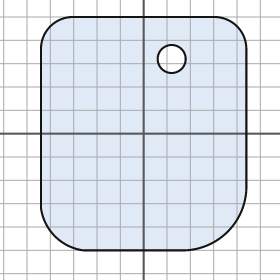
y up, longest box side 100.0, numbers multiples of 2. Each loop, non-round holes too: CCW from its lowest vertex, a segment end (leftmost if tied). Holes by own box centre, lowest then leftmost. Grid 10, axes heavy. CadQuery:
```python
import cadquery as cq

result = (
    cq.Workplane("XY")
    .moveTo(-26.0, -50.0)
    .lineTo(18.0, -50.0)
    .threePointArc((36.0, -42.0), (44.0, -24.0))
    .lineTo(44.0, 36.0)
    .threePointArc((40.0, 46.0), (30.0, 50.0))
    .lineTo(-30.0, 50.0)
    .threePointArc((-40.0, 46.0), (-44.0, 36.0))
    .lineTo(-44.0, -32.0)
    .threePointArc((-38.0, -44.0), (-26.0, -50.0))
    .close()
    .moveTo(12.0, 32.0)
    .circle(6.0)
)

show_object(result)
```